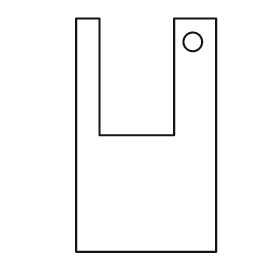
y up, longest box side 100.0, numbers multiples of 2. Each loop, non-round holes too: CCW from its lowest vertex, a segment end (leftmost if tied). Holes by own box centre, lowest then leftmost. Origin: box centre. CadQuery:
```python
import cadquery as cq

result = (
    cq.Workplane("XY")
    .moveTo(-30.0, -50.0)
    .lineTo(30.0, -50.0)
    .lineTo(30.0, 50.0)
    .lineTo(12.0, 50.0)
    .lineTo(12.0, 0.0)
    .lineTo(-20.0, 0.0)
    .lineTo(-20.0, 50.0)
    .lineTo(-30.0, 50.0)
    .close()
    .moveTo(20.0, 40.0)
    .circle(4.0)
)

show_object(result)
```